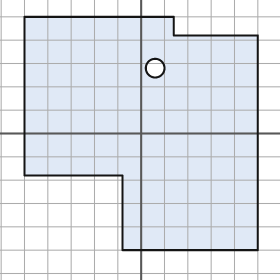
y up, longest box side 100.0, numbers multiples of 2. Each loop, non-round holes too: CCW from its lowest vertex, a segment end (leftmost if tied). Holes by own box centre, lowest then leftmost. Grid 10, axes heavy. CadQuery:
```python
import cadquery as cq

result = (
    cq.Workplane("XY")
    .moveTo(-8.0, -50.0)
    .lineTo(50.0, -50.0)
    .lineTo(50.0, 42.0)
    .lineTo(14.0, 42.0)
    .lineTo(14.0, 50.0)
    .lineTo(-50.0, 50.0)
    .lineTo(-50.0, -18.0)
    .lineTo(-8.0, -18.0)
    .close()
    .moveTo(6.0, 28.0)
    .circle(4.0)
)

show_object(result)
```